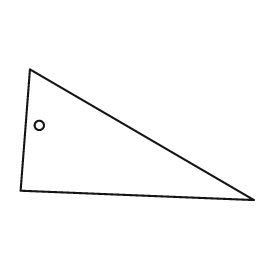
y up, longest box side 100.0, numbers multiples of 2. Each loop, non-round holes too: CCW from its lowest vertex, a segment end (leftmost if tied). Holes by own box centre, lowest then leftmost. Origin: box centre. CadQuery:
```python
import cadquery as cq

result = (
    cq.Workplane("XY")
    .moveTo(50.0, -28.0)
    .lineTo(-46.0, 28.0)
    .lineTo(-50.0, -24.0)
    .close()
    .moveTo(-42.0, 4.0)
    .circle(2.0)
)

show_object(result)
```